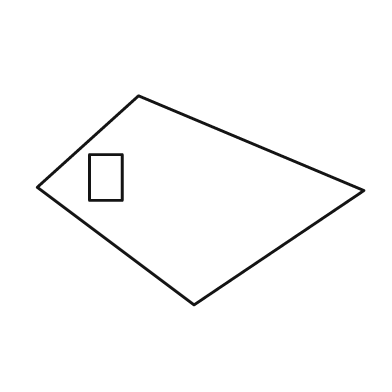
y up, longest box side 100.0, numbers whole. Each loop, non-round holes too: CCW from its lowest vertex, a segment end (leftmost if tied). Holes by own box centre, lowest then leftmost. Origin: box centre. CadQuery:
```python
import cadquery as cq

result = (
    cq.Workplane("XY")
    .moveTo(-2.0, -32.0)
    .lineTo(50.0, 3.0)
    .lineTo(-19.0, 32.0)
    .lineTo(-50.0, 4.0)
    .close()
    .moveTo(-34.0, 0.0)
    .lineTo(-24.0, 0.0)
    .lineTo(-24.0, 14.0)
    .lineTo(-34.0, 14.0)
    .close()
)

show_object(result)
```